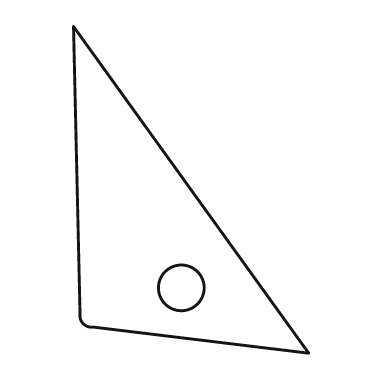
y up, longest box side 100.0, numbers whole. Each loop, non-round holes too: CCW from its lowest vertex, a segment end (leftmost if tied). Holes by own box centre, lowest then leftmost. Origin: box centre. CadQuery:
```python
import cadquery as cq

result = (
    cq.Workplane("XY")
    .moveTo(36.0, -50.0)
    .lineTo(-36.0, 50.0)
    .lineTo(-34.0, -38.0)
    .threePointArc((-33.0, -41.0), (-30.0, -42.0))
    .close()
    .moveTo(-3.0, -30.0)
    .circle(7.0)
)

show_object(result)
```